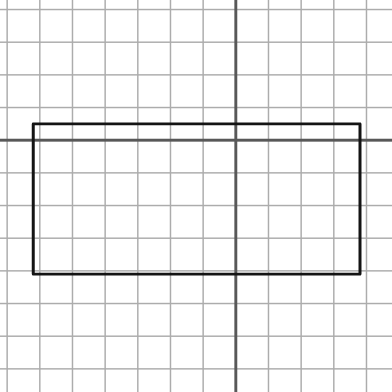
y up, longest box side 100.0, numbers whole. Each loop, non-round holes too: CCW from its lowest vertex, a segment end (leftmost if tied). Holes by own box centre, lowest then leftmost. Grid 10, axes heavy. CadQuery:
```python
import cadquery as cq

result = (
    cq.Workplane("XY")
    .moveTo(-62.0, -41.0)
    .lineTo(38.0, -41.0)
    .lineTo(38.0, 5.0)
    .lineTo(-62.0, 5.0)
    .close()
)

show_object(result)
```